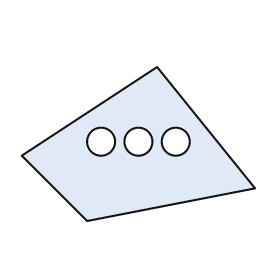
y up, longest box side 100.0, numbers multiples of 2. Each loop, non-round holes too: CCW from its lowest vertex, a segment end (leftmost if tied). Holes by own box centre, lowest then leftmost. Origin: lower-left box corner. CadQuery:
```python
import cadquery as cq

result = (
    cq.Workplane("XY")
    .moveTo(28.0, 0.0)
    .lineTo(100.0, 14.0)
    .lineTo(58.0, 66.0)
    .lineTo(0.0, 28.0)
    .close()
    .moveTo(34.0, 34.0)
    .circle(6.0)
    .moveTo(50.0, 34.0)
    .circle(6.0)
    .moveTo(66.0, 34.0)
    .circle(6.0)
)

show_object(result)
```